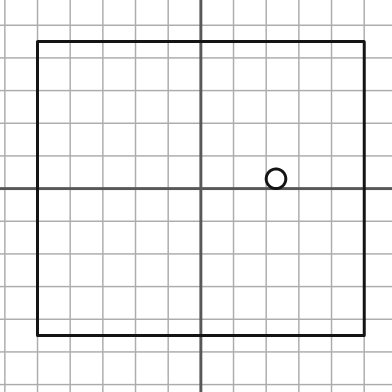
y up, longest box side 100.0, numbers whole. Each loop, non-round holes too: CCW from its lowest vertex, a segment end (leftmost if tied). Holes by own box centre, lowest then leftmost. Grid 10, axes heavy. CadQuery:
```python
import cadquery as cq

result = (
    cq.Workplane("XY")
    .moveTo(-50.0, -45.0)
    .lineTo(50.0, -45.0)
    .lineTo(50.0, 45.0)
    .lineTo(-50.0, 45.0)
    .close()
    .moveTo(23.0, 3.0)
    .circle(3.0)
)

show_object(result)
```